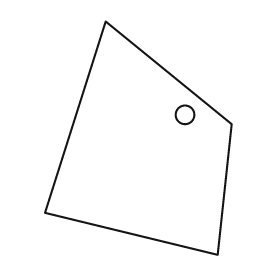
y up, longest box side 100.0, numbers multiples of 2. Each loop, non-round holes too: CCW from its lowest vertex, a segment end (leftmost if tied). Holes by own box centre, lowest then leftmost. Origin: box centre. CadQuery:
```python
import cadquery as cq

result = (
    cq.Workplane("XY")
    .moveTo(34.0, -50.0)
    .lineTo(40.0, 6.0)
    .lineTo(-14.0, 50.0)
    .lineTo(-40.0, -32.0)
    .close()
    .moveTo(20.0, 10.0)
    .circle(4.0)
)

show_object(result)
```